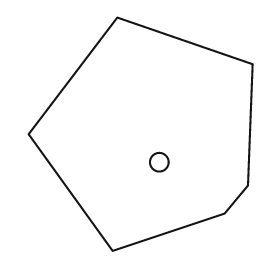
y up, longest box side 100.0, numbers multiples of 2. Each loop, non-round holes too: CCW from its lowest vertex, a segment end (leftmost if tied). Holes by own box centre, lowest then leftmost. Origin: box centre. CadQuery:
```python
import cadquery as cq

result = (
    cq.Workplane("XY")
    .moveTo(-12.0, -50.0)
    .lineTo(36.0, -34.0)
    .lineTo(46.0, -22.0)
    .lineTo(48.0, 30.0)
    .lineTo(-10.0, 50.0)
    .lineTo(-48.0, 0.0)
    .close()
    .moveTo(8.0, -12.0)
    .circle(4.0)
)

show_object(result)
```